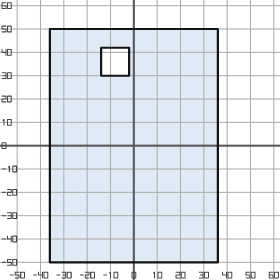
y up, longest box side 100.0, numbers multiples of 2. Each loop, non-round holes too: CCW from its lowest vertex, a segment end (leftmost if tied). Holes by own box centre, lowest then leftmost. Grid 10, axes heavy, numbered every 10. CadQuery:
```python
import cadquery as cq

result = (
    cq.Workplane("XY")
    .moveTo(-36.0, -50.0)
    .lineTo(36.0, -50.0)
    .lineTo(36.0, 50.0)
    .lineTo(-36.0, 50.0)
    .close()
    .moveTo(-14.0, 30.0)
    .lineTo(-2.0, 30.0)
    .lineTo(-2.0, 42.0)
    .lineTo(-14.0, 42.0)
    .close()
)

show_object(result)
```